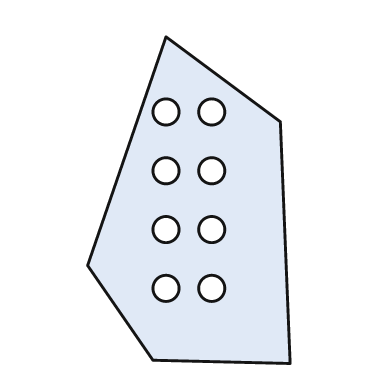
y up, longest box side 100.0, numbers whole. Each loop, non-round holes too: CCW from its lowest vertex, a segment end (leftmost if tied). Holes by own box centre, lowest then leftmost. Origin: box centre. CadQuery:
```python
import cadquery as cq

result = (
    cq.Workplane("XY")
    .moveTo(31.0, -50.0)
    .lineTo(28.0, 24.0)
    .lineTo(-7.0, 50.0)
    .lineTo(-31.0, -20.0)
    .lineTo(-11.0, -49.0)
    .close()
    .moveTo(-7.0, -27.0)
    .circle(4.0)
    .moveTo(7.0, -27.0)
    .circle(4.0)
    .moveTo(-7.0, -9.0)
    .circle(4.0)
    .moveTo(7.0, -9.0)
    .circle(4.0)
    .moveTo(-7.0, 9.0)
    .circle(4.0)
    .moveTo(7.0, 9.0)
    .circle(4.0)
    .moveTo(-7.0, 27.0)
    .circle(4.0)
    .moveTo(7.0, 27.0)
    .circle(4.0)
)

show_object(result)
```